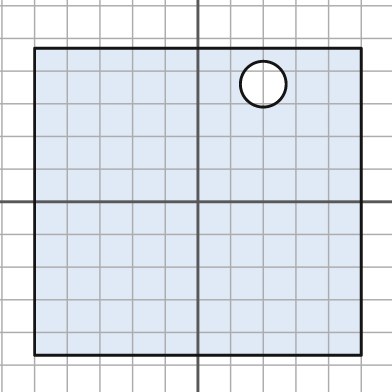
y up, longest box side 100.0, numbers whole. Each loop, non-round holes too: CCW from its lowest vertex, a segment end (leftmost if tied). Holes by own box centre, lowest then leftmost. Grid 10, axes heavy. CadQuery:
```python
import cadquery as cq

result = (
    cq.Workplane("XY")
    .moveTo(-50.0, -47.0)
    .lineTo(50.0, -47.0)
    .lineTo(50.0, 47.0)
    .lineTo(-50.0, 47.0)
    .close()
    .moveTo(20.0, 36.0)
    .circle(7.0)
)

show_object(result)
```